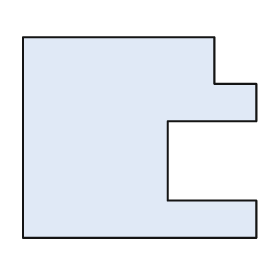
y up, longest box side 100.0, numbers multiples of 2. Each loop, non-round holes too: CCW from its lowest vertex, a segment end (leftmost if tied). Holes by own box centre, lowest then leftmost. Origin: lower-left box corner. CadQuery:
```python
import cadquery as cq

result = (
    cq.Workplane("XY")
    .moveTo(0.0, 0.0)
    .lineTo(100.0, 0.0)
    .lineTo(100.0, 16.0)
    .lineTo(62.0, 16.0)
    .lineTo(62.0, 50.0)
    .lineTo(100.0, 50.0)
    .lineTo(100.0, 66.0)
    .lineTo(82.0, 66.0)
    .lineTo(82.0, 86.0)
    .lineTo(0.0, 86.0)
    .close()
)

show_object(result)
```